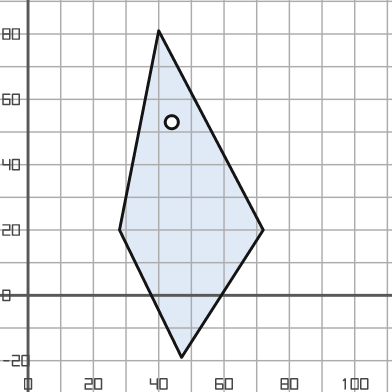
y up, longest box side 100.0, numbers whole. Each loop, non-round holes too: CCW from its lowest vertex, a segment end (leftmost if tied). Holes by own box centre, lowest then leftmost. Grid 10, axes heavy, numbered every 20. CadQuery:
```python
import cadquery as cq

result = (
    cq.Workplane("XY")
    .moveTo(47.0, -19.0)
    .lineTo(72.0, 20.0)
    .lineTo(40.0, 81.0)
    .lineTo(28.0, 20.0)
    .close()
    .moveTo(44.0, 53.0)
    .circle(2.0)
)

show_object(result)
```